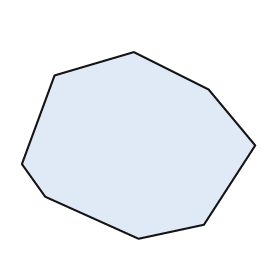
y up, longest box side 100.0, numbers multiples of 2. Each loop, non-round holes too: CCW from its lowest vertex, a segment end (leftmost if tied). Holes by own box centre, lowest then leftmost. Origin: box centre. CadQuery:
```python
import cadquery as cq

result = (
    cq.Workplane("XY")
    .moveTo(0.0, -40.0)
    .lineTo(28.0, -34.0)
    .lineTo(50.0, 0.0)
    .lineTo(30.0, 24.0)
    .lineTo(-2.0, 40.0)
    .lineTo(-36.0, 30.0)
    .lineTo(-50.0, -8.0)
    .lineTo(-40.0, -22.0)
    .close()
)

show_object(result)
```